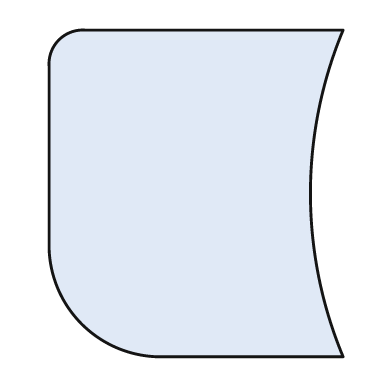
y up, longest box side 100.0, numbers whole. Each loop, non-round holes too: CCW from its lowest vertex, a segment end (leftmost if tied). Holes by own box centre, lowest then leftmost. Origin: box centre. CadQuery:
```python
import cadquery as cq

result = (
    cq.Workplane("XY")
    .moveTo(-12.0, -50.0)
    .lineTo(45.0, -50.0)
    .threePointArc((35.0, 0.0), (45.0, 50.0))
    .lineTo(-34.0, 50.0)
    .threePointArc((-42.0, 47.0), (-45.0, 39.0))
    .lineTo(-45.0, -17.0)
    .threePointArc((-35.0, -40.0), (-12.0, -50.0))
    .close()
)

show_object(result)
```